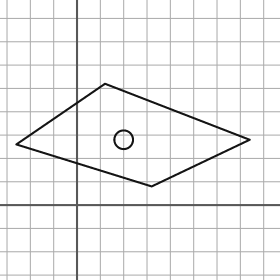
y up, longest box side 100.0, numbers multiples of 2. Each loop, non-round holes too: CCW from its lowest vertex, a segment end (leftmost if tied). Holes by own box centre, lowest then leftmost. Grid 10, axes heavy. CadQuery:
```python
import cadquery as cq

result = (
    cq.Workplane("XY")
    .moveTo(32.0, 8.0)
    .lineTo(74.0, 28.0)
    .lineTo(12.0, 52.0)
    .lineTo(-26.0, 26.0)
    .close()
    .moveTo(20.0, 28.0)
    .circle(4.0)
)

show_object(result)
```